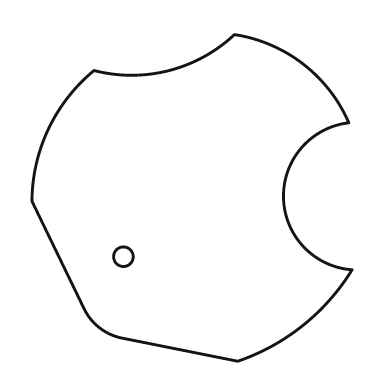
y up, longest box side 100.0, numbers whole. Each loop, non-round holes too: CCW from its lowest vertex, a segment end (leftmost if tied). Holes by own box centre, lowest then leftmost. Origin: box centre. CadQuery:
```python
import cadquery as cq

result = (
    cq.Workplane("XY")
    .moveTo(14.0, -50.0)
    .threePointArc((34.0, -39.0), (49.0, -22.0))
    .threePointArc((28.0, 0.0), (48.0, 23.0))
    .threePointArc((34.0, 41.0), (13.0, 50.0))
    .threePointArc((-7.0, 39.0), (-30.0, 39.0))
    .threePointArc((-44.0, 21.0), (-49.0, -1.0))
    .lineTo(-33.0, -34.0)
    .threePointArc((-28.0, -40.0), (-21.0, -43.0))
    .close()
    .moveTo(-21.0, -18.0)
    .circle(3.0)
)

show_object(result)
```